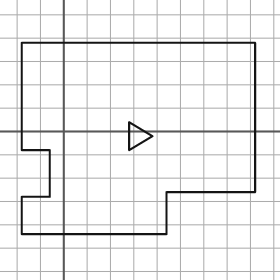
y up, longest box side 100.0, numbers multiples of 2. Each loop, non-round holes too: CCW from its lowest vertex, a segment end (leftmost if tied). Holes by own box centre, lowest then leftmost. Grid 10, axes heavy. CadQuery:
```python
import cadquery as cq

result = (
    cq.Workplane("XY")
    .moveTo(-18.0, -44.0)
    .lineTo(44.0, -44.0)
    .lineTo(44.0, -26.0)
    .lineTo(82.0, -26.0)
    .lineTo(82.0, 38.0)
    .lineTo(-18.0, 38.0)
    .lineTo(-18.0, -8.0)
    .lineTo(-6.0, -8.0)
    .lineTo(-6.0, -28.0)
    .lineTo(-18.0, -28.0)
    .close()
    .moveTo(28.0, -8.0)
    .lineTo(38.0, -2.0)
    .lineTo(28.0, 4.0)
    .close()
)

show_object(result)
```